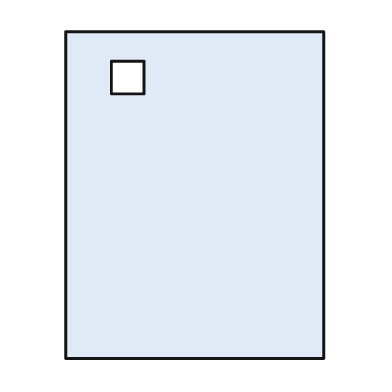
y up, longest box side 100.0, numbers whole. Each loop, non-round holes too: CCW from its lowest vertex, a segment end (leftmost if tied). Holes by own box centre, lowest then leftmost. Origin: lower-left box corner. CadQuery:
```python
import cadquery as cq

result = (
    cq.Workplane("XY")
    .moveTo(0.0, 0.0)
    .lineTo(79.0, 0.0)
    .lineTo(79.0, 100.0)
    .lineTo(0.0, 100.0)
    .close()
    .moveTo(14.0, 81.0)
    .lineTo(24.0, 81.0)
    .lineTo(24.0, 91.0)
    .lineTo(14.0, 91.0)
    .close()
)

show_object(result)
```